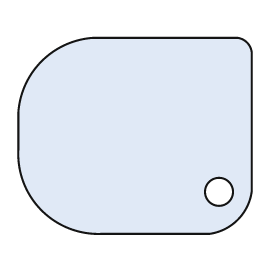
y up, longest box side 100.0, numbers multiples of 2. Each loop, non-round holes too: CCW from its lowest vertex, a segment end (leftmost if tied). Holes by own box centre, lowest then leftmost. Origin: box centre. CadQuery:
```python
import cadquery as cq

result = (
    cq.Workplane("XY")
    .moveTo(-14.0, -42.0)
    .lineTo(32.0, -42.0)
    .threePointArc((44.0, -36.0), (50.0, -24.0))
    .lineTo(50.0, 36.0)
    .threePointArc((48.0, 40.0), (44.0, 42.0))
    .lineTo(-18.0, 42.0)
    .threePointArc((-40.0, 32.0), (-50.0, 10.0))
    .lineTo(-50.0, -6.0)
    .threePointArc((-40.0, -32.0), (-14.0, -42.0))
    .close()
    .moveTo(36.0, -24.0)
    .circle(6.0)
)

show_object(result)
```